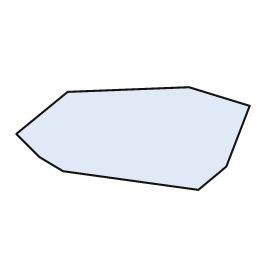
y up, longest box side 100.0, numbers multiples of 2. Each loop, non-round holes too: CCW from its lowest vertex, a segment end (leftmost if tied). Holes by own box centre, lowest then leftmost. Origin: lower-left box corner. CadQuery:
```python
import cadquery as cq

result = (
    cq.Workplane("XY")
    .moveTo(78.0, 0.0)
    .lineTo(90.0, 10.0)
    .lineTo(100.0, 36.0)
    .lineTo(74.0, 44.0)
    .lineTo(22.0, 42.0)
    .lineTo(0.0, 24.0)
    .lineTo(10.0, 14.0)
    .lineTo(20.0, 8.0)
    .close()
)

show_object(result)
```